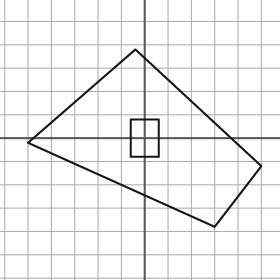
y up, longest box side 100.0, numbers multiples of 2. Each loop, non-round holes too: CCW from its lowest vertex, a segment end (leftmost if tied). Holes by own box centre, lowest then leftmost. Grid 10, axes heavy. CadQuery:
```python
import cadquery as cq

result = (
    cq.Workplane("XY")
    .moveTo(30.0, -38.0)
    .lineTo(50.0, -12.0)
    .lineTo(-4.0, 38.0)
    .lineTo(-50.0, -2.0)
    .close()
    .moveTo(-6.0, -8.0)
    .lineTo(6.0, -8.0)
    .lineTo(6.0, 8.0)
    .lineTo(-6.0, 8.0)
    .close()
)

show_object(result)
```